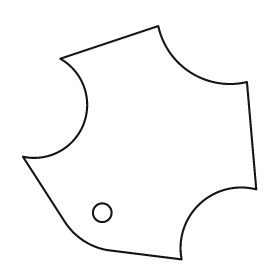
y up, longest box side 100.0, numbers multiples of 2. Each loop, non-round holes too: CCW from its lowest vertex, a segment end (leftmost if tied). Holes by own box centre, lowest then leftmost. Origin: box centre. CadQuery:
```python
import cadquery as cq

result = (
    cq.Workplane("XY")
    .moveTo(18.0, -50.0)
    .threePointArc((26.0, -26.0), (50.0, -20.0))
    .lineTo(46.0, 26.0)
    .threePointArc((22.0, 30.0), (8.0, 50.0))
    .lineTo(-34.0, 36.0)
    .threePointArc((-24.0, 8.0), (-50.0, -6.0))
    .lineTo(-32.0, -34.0)
    .threePointArc((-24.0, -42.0), (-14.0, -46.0))
    .close()
    .moveTo(-16.0, -30.0)
    .circle(4.0)
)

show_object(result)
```